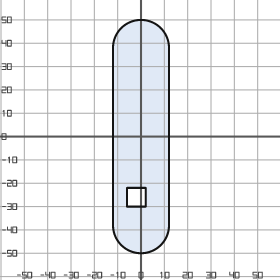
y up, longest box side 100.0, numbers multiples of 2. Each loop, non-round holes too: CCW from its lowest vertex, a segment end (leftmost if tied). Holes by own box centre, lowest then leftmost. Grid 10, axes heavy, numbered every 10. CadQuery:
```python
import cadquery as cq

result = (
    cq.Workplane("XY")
    .moveTo(-12.0, -38.0)
    .threePointArc((0.0, -50.0), (12.0, -38.0))
    .lineTo(12.0, 38.0)
    .threePointArc((0.0, 50.0), (-12.0, 38.0))
    .close()
    .moveTo(-6.0, -30.0)
    .lineTo(2.0, -30.0)
    .lineTo(2.0, -22.0)
    .lineTo(-6.0, -22.0)
    .close()
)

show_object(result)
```